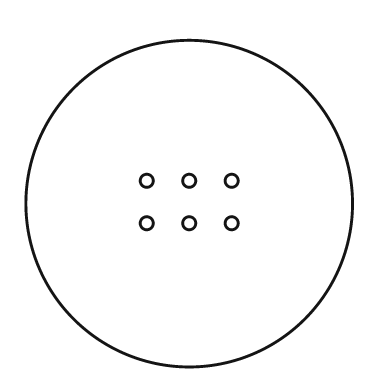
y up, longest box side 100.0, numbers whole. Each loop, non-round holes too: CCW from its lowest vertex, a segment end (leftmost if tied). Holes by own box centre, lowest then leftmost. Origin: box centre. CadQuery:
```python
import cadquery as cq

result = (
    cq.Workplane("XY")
    .moveTo(0.0, 0.0)
    .circle(50.0)
    .moveTo(-13.0, -6.0)
    .circle(2.0)
    .moveTo(0.0, -6.0)
    .circle(2.0)
    .moveTo(13.0, -6.0)
    .circle(2.0)
    .moveTo(-13.0, 7.0)
    .circle(2.0)
    .moveTo(0.0, 7.0)
    .circle(2.0)
    .moveTo(13.0, 7.0)
    .circle(2.0)
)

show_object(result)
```